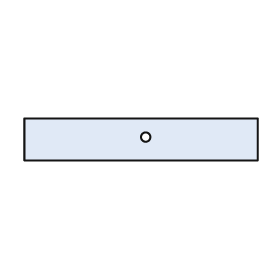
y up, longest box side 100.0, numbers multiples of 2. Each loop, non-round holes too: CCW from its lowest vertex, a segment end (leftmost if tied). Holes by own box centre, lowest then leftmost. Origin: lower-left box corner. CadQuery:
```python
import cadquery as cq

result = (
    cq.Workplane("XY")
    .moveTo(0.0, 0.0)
    .lineTo(100.0, 0.0)
    .lineTo(100.0, 18.0)
    .lineTo(0.0, 18.0)
    .close()
    .moveTo(52.0, 10.0)
    .circle(2.0)
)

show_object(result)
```